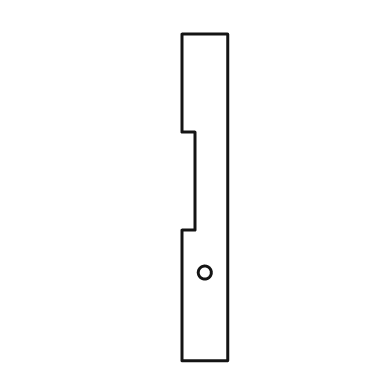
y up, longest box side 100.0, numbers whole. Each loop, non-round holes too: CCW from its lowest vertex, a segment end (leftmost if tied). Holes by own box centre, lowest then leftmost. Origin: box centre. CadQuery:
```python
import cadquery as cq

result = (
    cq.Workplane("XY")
    .moveTo(-7.0, -50.0)
    .lineTo(7.0, -50.0)
    .lineTo(7.0, 50.0)
    .lineTo(-7.0, 50.0)
    .lineTo(-7.0, 20.0)
    .lineTo(-3.0, 20.0)
    .lineTo(-3.0, -10.0)
    .lineTo(-7.0, -10.0)
    .close()
    .moveTo(0.0, -23.0)
    .circle(2.0)
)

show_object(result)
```